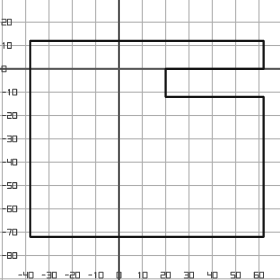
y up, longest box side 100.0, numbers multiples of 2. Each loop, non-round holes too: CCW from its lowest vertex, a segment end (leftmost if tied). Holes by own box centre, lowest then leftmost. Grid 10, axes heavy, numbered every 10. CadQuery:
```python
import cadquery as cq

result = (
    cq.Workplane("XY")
    .moveTo(-38.0, -72.0)
    .lineTo(62.0, -72.0)
    .lineTo(62.0, -12.0)
    .lineTo(20.0, -12.0)
    .lineTo(20.0, 0.0)
    .lineTo(62.0, 0.0)
    .lineTo(62.0, 12.0)
    .lineTo(-38.0, 12.0)
    .close()
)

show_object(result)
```